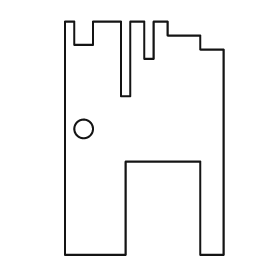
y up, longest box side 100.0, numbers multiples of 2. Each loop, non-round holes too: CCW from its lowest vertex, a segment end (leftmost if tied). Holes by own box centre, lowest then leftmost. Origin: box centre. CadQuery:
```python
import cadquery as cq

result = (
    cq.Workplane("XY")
    .moveTo(-34.0, -50.0)
    .lineTo(-8.0, -50.0)
    .lineTo(-8.0, -10.0)
    .lineTo(24.0, -10.0)
    .lineTo(24.0, -50.0)
    .lineTo(34.0, -50.0)
    .lineTo(34.0, 38.0)
    .lineTo(24.0, 38.0)
    .lineTo(24.0, 44.0)
    .lineTo(10.0, 44.0)
    .lineTo(10.0, 50.0)
    .lineTo(4.0, 50.0)
    .lineTo(4.0, 34.0)
    .lineTo(0.0, 34.0)
    .lineTo(0.0, 50.0)
    .lineTo(-6.0, 50.0)
    .lineTo(-6.0, 18.0)
    .lineTo(-10.0, 18.0)
    .lineTo(-10.0, 50.0)
    .lineTo(-22.0, 50.0)
    .lineTo(-22.0, 40.0)
    .lineTo(-30.0, 40.0)
    .lineTo(-30.0, 50.0)
    .lineTo(-34.0, 50.0)
    .close()
    .moveTo(-26.0, 4.0)
    .circle(4.0)
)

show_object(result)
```